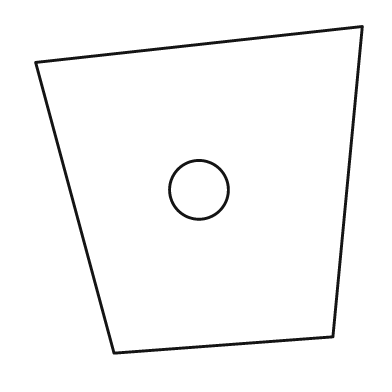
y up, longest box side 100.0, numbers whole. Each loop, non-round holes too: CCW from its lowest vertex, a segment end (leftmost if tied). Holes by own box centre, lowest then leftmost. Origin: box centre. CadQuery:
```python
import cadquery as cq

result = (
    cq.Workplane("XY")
    .moveTo(-26.0, -50.0)
    .lineTo(41.0, -45.0)
    .lineTo(50.0, 50.0)
    .lineTo(-50.0, 39.0)
    .close()
    .moveTo(0.0, 0.0)
    .circle(9.0)
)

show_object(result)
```